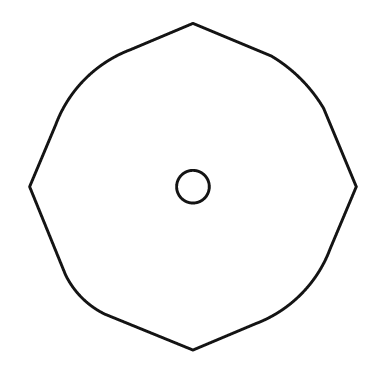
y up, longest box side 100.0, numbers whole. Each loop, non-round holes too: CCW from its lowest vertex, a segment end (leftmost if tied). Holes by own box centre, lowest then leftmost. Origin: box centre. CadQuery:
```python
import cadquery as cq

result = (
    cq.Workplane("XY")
    .moveTo(0.0, -50.0)
    .lineTo(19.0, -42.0)
    .threePointArc((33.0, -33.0), (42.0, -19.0))
    .lineTo(50.0, 0.0)
    .lineTo(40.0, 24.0)
    .threePointArc((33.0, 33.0), (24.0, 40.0))
    .lineTo(0.0, 50.0)
    .lineTo(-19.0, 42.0)
    .threePointArc((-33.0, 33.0), (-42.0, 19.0))
    .lineTo(-50.0, 0.0)
    .lineTo(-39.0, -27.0)
    .threePointArc((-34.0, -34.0), (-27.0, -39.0))
    .close()
    .moveTo(0.0, 0.0)
    .circle(5.0)
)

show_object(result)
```